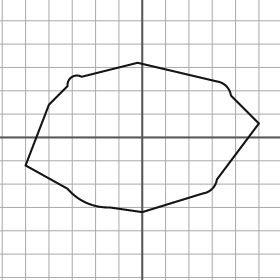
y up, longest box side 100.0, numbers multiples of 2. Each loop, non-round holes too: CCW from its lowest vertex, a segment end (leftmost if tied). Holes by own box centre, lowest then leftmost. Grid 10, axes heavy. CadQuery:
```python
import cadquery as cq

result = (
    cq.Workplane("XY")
    .moveTo(0.0, -32.0)
    .lineTo(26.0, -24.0)
    .threePointArc((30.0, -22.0), (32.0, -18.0))
    .lineTo(50.0, 6.0)
    .lineTo(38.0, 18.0)
    .threePointArc((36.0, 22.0), (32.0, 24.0))
    .lineTo(-2.0, 32.0)
    .lineTo(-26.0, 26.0)
    .threePointArc((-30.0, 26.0), (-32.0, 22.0))
    .lineTo(-40.0, 14.0)
    .lineTo(-50.0, -12.0)
    .lineTo(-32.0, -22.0)
    .threePointArc((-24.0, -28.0), (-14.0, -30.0))
    .close()
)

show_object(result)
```